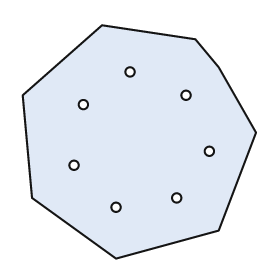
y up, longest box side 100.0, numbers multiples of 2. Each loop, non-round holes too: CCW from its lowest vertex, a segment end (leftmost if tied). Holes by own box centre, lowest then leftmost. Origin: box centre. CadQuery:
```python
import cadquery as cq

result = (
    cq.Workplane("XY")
    .moveTo(-10.0, -50.0)
    .lineTo(34.0, -38.0)
    .lineTo(50.0, 4.0)
    .lineTo(34.0, 32.0)
    .lineTo(24.0, 44.0)
    .lineTo(-16.0, 50.0)
    .lineTo(-50.0, 20.0)
    .lineTo(-46.0, -24.0)
    .close()
    .moveTo(-10.0, -28.0)
    .circle(2.0)
    .moveTo(16.0, -24.0)
    .circle(2.0)
    .moveTo(-28.0, -10.0)
    .circle(2.0)
    .moveTo(30.0, -4.0)
    .circle(2.0)
    .moveTo(-24.0, 16.0)
    .circle(2.0)
    .moveTo(20.0, 20.0)
    .circle(2.0)
    .moveTo(-4.0, 30.0)
    .circle(2.0)
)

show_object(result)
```